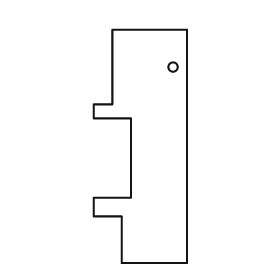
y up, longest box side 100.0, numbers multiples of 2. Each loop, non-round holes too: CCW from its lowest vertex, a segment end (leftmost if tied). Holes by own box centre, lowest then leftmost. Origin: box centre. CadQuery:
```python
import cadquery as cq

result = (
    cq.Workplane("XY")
    .moveTo(-8.0, -50.0)
    .lineTo(20.0, -50.0)
    .lineTo(20.0, 50.0)
    .lineTo(-12.0, 50.0)
    .lineTo(-12.0, 18.0)
    .lineTo(-20.0, 18.0)
    .lineTo(-20.0, 12.0)
    .lineTo(-4.0, 12.0)
    .lineTo(-4.0, -22.0)
    .lineTo(-20.0, -22.0)
    .lineTo(-20.0, -30.0)
    .lineTo(-8.0, -30.0)
    .close()
    .moveTo(14.0, 34.0)
    .circle(2.0)
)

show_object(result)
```